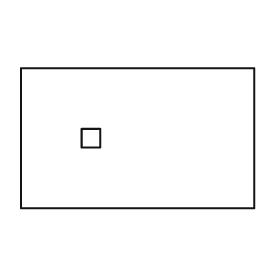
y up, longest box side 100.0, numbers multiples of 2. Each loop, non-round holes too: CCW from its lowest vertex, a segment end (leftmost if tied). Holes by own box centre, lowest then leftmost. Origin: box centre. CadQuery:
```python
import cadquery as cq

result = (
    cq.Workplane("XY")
    .moveTo(-50.0, -30.0)
    .lineTo(50.0, -30.0)
    .lineTo(50.0, 30.0)
    .lineTo(-50.0, 30.0)
    .close()
    .moveTo(-24.0, -4.0)
    .lineTo(-16.0, -4.0)
    .lineTo(-16.0, 4.0)
    .lineTo(-24.0, 4.0)
    .close()
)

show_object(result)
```